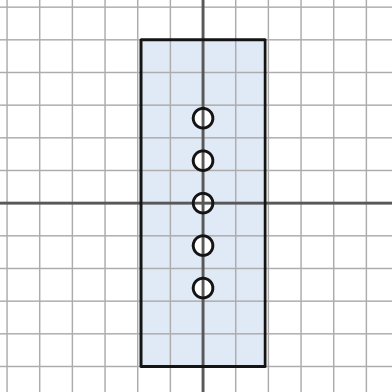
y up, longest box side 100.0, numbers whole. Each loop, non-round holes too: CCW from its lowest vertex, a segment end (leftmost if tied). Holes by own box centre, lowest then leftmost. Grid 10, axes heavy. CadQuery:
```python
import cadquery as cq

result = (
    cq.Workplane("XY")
    .moveTo(-19.0, -50.0)
    .lineTo(19.0, -50.0)
    .lineTo(19.0, 50.0)
    .lineTo(-19.0, 50.0)
    .close()
    .moveTo(0.0, -26.0)
    .circle(3.0)
    .moveTo(0.0, -13.0)
    .circle(3.0)
    .moveTo(0.0, 0.0)
    .circle(3.0)
    .moveTo(0.0, 13.0)
    .circle(3.0)
    .moveTo(0.0, 26.0)
    .circle(3.0)
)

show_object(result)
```